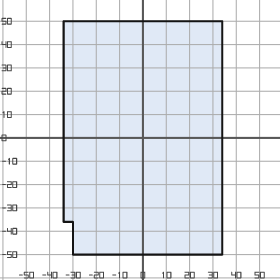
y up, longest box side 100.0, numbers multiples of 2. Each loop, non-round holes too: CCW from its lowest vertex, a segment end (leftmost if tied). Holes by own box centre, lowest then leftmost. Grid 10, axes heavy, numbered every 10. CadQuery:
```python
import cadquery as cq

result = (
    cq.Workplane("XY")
    .moveTo(-30.0, -50.0)
    .lineTo(34.0, -50.0)
    .lineTo(34.0, 50.0)
    .lineTo(-34.0, 50.0)
    .lineTo(-34.0, -36.0)
    .lineTo(-30.0, -36.0)
    .close()
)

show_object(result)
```